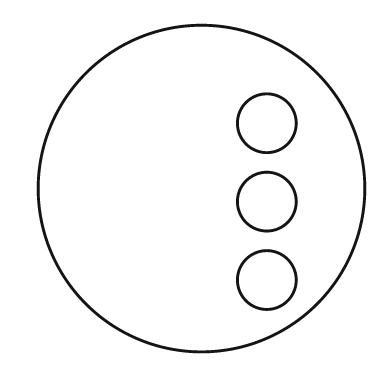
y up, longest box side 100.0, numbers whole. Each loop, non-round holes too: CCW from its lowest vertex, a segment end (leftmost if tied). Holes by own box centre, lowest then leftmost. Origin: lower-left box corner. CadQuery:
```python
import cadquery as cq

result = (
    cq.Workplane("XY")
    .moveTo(50.0, 50.0)
    .circle(50.0)
    .moveTo(70.0, 22.0)
    .circle(9.0)
    .moveTo(70.0, 46.0)
    .circle(9.0)
    .moveTo(70.0, 70.0)
    .circle(9.0)
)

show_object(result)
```